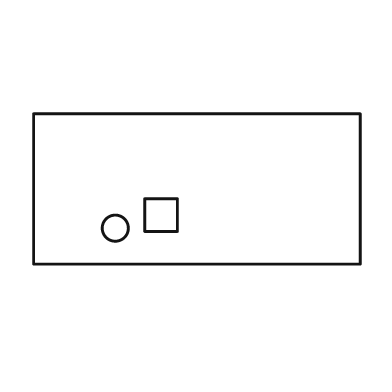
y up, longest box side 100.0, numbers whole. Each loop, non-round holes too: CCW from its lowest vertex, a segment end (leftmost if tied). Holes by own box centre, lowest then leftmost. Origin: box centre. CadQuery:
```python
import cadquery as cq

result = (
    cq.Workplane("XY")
    .moveTo(-50.0, -23.0)
    .lineTo(50.0, -23.0)
    .lineTo(50.0, 23.0)
    .lineTo(-50.0, 23.0)
    .close()
    .moveTo(-25.0, -12.0)
    .circle(4.0)
    .moveTo(-16.0, -13.0)
    .lineTo(-6.0, -13.0)
    .lineTo(-6.0, -3.0)
    .lineTo(-16.0, -3.0)
    .close()
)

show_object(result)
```